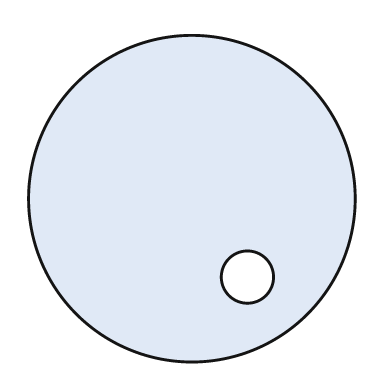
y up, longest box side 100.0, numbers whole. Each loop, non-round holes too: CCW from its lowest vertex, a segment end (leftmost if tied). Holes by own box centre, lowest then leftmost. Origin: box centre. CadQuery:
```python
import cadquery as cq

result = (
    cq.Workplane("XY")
    .moveTo(0.0, 0.0)
    .circle(50.0)
    .moveTo(17.0, -24.0)
    .circle(8.0)
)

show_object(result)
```